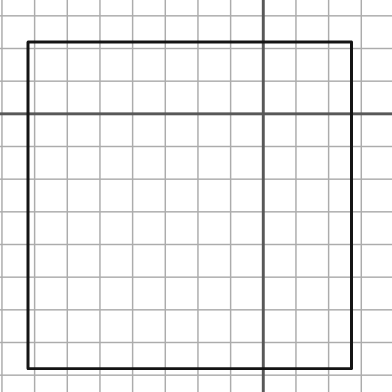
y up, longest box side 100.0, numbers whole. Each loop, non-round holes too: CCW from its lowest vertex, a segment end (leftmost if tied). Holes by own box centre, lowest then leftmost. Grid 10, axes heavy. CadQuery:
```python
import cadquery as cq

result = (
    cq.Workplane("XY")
    .moveTo(-72.0, -78.0)
    .lineTo(27.0, -78.0)
    .lineTo(27.0, 22.0)
    .lineTo(-72.0, 22.0)
    .close()
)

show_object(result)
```